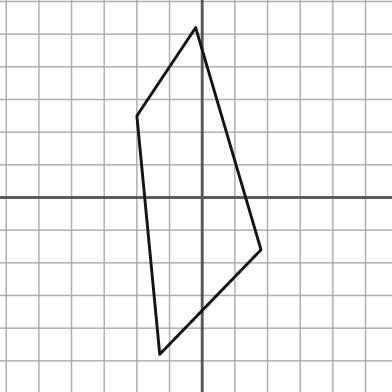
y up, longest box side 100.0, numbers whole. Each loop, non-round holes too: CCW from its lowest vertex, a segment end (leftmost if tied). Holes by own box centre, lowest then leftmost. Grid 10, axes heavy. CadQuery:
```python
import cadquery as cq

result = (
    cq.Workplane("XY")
    .moveTo(-13.0, -48.0)
    .lineTo(18.0, -16.0)
    .lineTo(-2.0, 52.0)
    .lineTo(-20.0, 25.0)
    .close()
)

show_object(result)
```